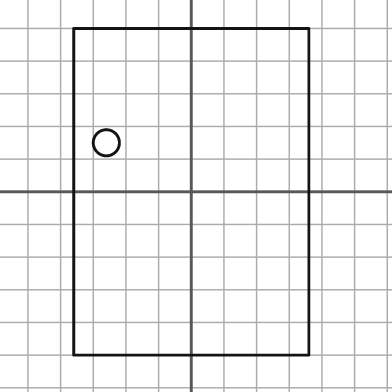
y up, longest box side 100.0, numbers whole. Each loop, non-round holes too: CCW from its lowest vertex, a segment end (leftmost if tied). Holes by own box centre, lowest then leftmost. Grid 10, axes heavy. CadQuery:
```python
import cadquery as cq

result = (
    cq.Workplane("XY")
    .moveTo(-36.0, -50.0)
    .lineTo(36.0, -50.0)
    .lineTo(36.0, 50.0)
    .lineTo(-36.0, 50.0)
    .close()
    .moveTo(-26.0, 15.0)
    .circle(4.0)
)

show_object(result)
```